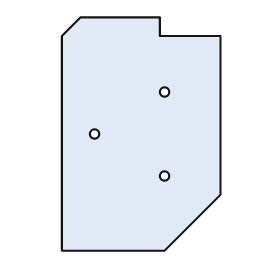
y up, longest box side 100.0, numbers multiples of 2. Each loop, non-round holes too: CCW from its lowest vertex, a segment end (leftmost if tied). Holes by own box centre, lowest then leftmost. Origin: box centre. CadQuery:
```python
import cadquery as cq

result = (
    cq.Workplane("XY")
    .moveTo(-34.0, -50.0)
    .lineTo(10.0, -50.0)
    .lineTo(34.0, -26.0)
    .lineTo(34.0, 42.0)
    .lineTo(8.0, 42.0)
    .lineTo(8.0, 50.0)
    .lineTo(-26.0, 50.0)
    .lineTo(-34.0, 42.0)
    .close()
    .moveTo(10.0, -18.0)
    .circle(2.0)
    .moveTo(-20.0, 0.0)
    .circle(2.0)
    .moveTo(10.0, 18.0)
    .circle(2.0)
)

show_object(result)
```